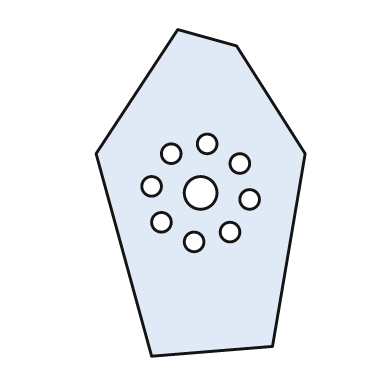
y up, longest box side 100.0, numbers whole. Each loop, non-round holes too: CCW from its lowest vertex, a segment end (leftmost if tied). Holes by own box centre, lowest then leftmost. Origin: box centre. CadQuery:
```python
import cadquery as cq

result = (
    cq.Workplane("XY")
    .moveTo(-15.0, -50.0)
    .lineTo(22.0, -47.0)
    .lineTo(32.0, 12.0)
    .lineTo(11.0, 45.0)
    .lineTo(-7.0, 50.0)
    .lineTo(-32.0, 12.0)
    .close()
    .moveTo(-2.0, -15.0)
    .circle(3.0)
    .moveTo(9.0, -12.0)
    .circle(3.0)
    .moveTo(-12.0, -9.0)
    .circle(3.0)
    .moveTo(15.0, -2.0)
    .circle(3.0)
    .moveTo(0.0, 0.0)
    .circle(5.0)
    .moveTo(-15.0, 2.0)
    .circle(3.0)
    .moveTo(12.0, 9.0)
    .circle(3.0)
    .moveTo(-9.0, 12.0)
    .circle(3.0)
    .moveTo(2.0, 15.0)
    .circle(3.0)
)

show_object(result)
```